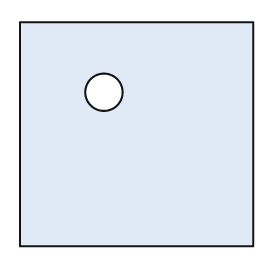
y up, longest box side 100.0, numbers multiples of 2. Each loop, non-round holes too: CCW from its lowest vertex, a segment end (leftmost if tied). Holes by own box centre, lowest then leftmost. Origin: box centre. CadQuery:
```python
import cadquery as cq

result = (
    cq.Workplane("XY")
    .moveTo(-50.0, -48.0)
    .lineTo(50.0, -48.0)
    .lineTo(50.0, 48.0)
    .lineTo(-50.0, 48.0)
    .close()
    .moveTo(-14.0, 18.0)
    .circle(8.0)
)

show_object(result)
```